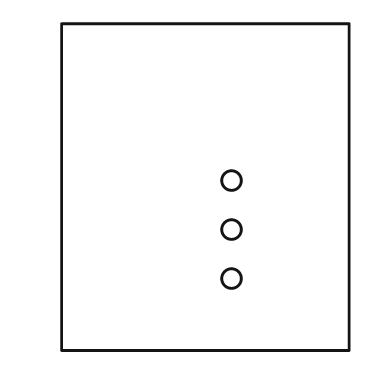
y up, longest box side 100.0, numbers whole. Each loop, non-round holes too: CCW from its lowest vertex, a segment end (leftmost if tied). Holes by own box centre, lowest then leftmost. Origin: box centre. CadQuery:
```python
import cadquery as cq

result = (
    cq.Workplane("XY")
    .moveTo(-44.0, -50.0)
    .lineTo(44.0, -50.0)
    .lineTo(44.0, 50.0)
    .lineTo(-44.0, 50.0)
    .close()
    .moveTo(8.0, -28.0)
    .circle(3.0)
    .moveTo(8.0, -13.0)
    .circle(3.0)
    .moveTo(8.0, 2.0)
    .circle(3.0)
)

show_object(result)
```